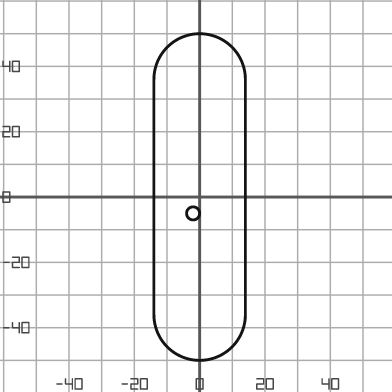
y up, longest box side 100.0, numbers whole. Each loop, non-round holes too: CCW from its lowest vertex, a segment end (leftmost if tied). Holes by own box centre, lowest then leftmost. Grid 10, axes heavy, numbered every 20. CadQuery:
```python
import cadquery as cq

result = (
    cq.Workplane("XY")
    .moveTo(-14.0, -36.0)
    .threePointArc((0.0, -50.0), (14.0, -36.0))
    .lineTo(14.0, 36.0)
    .threePointArc((0.0, 50.0), (-14.0, 36.0))
    .close()
    .moveTo(-2.0, -5.0)
    .circle(2.0)
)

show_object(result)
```